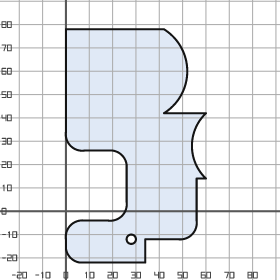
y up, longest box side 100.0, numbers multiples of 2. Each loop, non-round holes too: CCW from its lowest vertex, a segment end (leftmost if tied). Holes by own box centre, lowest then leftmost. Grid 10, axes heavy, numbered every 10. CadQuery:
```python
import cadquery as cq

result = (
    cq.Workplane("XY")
    .moveTo(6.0, -22.0)
    .lineTo(34.0, -22.0)
    .lineTo(34.0, -12.0)
    .lineTo(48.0, -12.0)
    .threePointArc((54.0, -10.0), (56.0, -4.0))
    .lineTo(56.0, 14.0)
    .lineTo(60.0, 14.0)
    .threePointArc((54.0, 28.0), (60.0, 42.0))
    .lineTo(42.0, 42.0)
    .threePointArc((52.0, 60.0), (42.0, 78.0))
    .lineTo(0.0, 78.0)
    .lineTo(0.0, 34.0)
    .threePointArc((2.0, 28.0), (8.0, 26.0))
    .lineTo(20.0, 26.0)
    .threePointArc((24.0, 24.0), (26.0, 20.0))
    .lineTo(26.0, 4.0)
    .threePointArc((24.0, -2.0), (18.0, -4.0))
    .lineTo(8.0, -4.0)
    .threePointArc((2.0, -6.0), (0.0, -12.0))
    .lineTo(0.0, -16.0)
    .threePointArc((2.0, -20.0), (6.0, -22.0))
    .close()
    .moveTo(28.0, -12.0)
    .circle(2.0)
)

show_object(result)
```